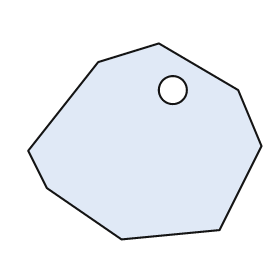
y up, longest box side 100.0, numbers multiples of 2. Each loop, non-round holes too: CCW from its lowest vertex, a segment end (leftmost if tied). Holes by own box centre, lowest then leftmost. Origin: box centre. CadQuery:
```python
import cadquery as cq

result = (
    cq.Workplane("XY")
    .moveTo(-10.0, -42.0)
    .lineTo(32.0, -38.0)
    .lineTo(50.0, -2.0)
    .lineTo(40.0, 22.0)
    .lineTo(6.0, 42.0)
    .lineTo(-20.0, 34.0)
    .lineTo(-50.0, -4.0)
    .lineTo(-42.0, -20.0)
    .close()
    .moveTo(12.0, 22.0)
    .circle(6.0)
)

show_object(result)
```